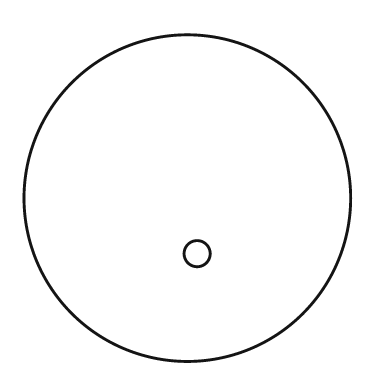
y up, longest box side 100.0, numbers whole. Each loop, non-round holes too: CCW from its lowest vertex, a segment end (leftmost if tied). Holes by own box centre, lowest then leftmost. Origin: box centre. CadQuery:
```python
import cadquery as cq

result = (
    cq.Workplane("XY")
    .moveTo(0.0, 0.0)
    .circle(50.0)
    .moveTo(3.0, -17.0)
    .circle(4.0)
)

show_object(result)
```